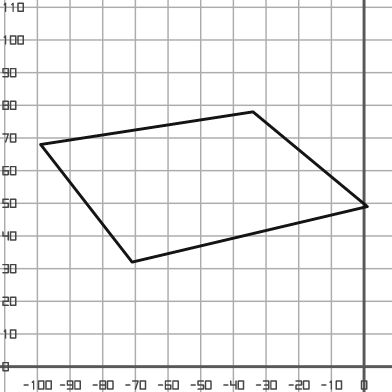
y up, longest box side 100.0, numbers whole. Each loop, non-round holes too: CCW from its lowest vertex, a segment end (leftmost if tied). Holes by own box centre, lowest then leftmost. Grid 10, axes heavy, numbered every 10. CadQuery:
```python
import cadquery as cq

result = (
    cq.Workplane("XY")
    .moveTo(-71.0, 32.0)
    .lineTo(1.0, 49.0)
    .lineTo(-34.0, 78.0)
    .lineTo(-99.0, 68.0)
    .close()
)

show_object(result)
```